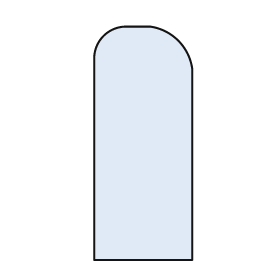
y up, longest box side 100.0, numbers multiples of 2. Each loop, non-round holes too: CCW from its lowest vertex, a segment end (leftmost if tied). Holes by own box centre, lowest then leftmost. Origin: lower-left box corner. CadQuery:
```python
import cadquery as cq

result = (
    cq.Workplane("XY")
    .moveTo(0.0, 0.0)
    .lineTo(42.0, 0.0)
    .lineTo(42.0, 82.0)
    .threePointArc((36.0, 94.0), (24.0, 100.0))
    .lineTo(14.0, 100.0)
    .threePointArc((4.0, 96.0), (0.0, 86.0))
    .close()
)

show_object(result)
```